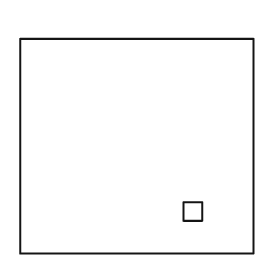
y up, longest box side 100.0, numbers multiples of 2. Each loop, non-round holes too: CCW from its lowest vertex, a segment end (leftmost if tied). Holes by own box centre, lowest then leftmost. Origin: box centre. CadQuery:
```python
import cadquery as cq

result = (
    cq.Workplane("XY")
    .moveTo(-50.0, -46.0)
    .lineTo(50.0, -46.0)
    .lineTo(50.0, 46.0)
    .lineTo(-50.0, 46.0)
    .close()
    .moveTo(20.0, -32.0)
    .lineTo(28.0, -32.0)
    .lineTo(28.0, -24.0)
    .lineTo(20.0, -24.0)
    .close()
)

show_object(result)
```